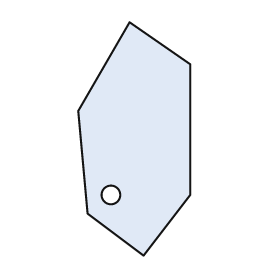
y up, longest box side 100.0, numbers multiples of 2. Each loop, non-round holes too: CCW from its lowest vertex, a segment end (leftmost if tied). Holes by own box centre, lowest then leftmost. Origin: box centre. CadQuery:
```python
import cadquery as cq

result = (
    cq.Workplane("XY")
    .moveTo(4.0, -50.0)
    .lineTo(24.0, -24.0)
    .lineTo(24.0, 32.0)
    .lineTo(-2.0, 50.0)
    .lineTo(-24.0, 12.0)
    .lineTo(-20.0, -32.0)
    .close()
    .moveTo(-10.0, -24.0)
    .circle(4.0)
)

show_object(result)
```